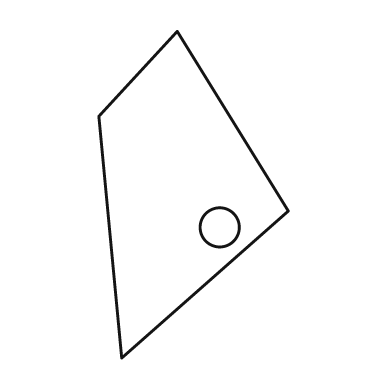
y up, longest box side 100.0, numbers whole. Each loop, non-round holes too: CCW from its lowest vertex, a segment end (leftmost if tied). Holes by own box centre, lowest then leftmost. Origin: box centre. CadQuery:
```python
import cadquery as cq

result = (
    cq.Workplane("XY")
    .moveTo(-22.0, -50.0)
    .lineTo(29.0, -5.0)
    .lineTo(-5.0, 50.0)
    .lineTo(-29.0, 24.0)
    .close()
    .moveTo(8.0, -10.0)
    .circle(6.0)
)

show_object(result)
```